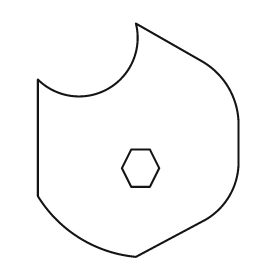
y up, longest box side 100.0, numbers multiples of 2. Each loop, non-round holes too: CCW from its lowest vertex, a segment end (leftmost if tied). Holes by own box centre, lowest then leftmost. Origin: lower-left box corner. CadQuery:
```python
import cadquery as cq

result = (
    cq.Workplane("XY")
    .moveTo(42.0, 0.0)
    .lineTo(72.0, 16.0)
    .threePointArc((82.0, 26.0), (86.0, 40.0))
    .lineTo(86.0, 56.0)
    .threePointArc((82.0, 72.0), (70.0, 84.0))
    .lineTo(42.0, 100.0)
    .threePointArc((30.0, 72.0), (0.0, 76.0))
    .lineTo(0.0, 26.0)
    .threePointArc((18.0, 8.0), (42.0, 0.0))
    .close()
    .moveTo(40.0, 30.0)
    .lineTo(48.0, 30.0)
    .lineTo(52.0, 38.0)
    .lineTo(48.0, 46.0)
    .lineTo(40.0, 46.0)
    .lineTo(36.0, 38.0)
    .close()
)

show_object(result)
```